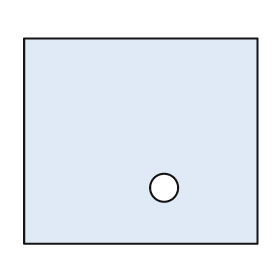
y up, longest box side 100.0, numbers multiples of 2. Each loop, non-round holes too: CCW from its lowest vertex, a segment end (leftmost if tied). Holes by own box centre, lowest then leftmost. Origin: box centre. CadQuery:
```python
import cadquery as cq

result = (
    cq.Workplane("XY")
    .moveTo(-50.0, -44.0)
    .lineTo(50.0, -44.0)
    .lineTo(50.0, 44.0)
    .lineTo(-50.0, 44.0)
    .close()
    .moveTo(10.0, -20.0)
    .circle(6.0)
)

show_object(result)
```